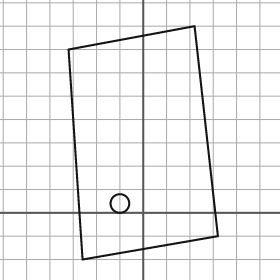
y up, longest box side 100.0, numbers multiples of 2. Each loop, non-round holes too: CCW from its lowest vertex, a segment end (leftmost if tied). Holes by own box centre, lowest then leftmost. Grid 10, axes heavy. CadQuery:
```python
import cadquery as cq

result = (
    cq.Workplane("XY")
    .moveTo(-26.0, -20.0)
    .lineTo(32.0, -10.0)
    .lineTo(22.0, 80.0)
    .lineTo(-32.0, 70.0)
    .close()
    .moveTo(-10.0, 4.0)
    .circle(4.0)
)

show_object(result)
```